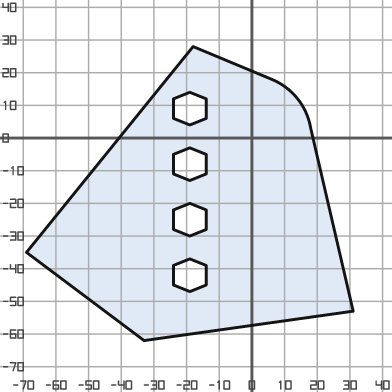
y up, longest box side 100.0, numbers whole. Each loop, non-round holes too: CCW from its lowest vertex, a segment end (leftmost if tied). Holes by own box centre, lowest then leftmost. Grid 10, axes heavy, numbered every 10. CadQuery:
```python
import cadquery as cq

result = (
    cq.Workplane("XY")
    .moveTo(-33.0, -62.0)
    .lineTo(31.0, -53.0)
    .lineTo(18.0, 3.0)
    .threePointArc((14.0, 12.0), (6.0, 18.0))
    .lineTo(-18.0, 28.0)
    .lineTo(-69.0, -35.0)
    .close()
    .moveTo(-19.0, -47.0)
    .lineTo(-14.0, -45.0)
    .lineTo(-14.0, -39.0)
    .lineTo(-19.0, -37.0)
    .lineTo(-24.0, -39.0)
    .lineTo(-24.0, -45.0)
    .close()
    .moveTo(-19.0, -30.0)
    .lineTo(-14.0, -28.0)
    .lineTo(-14.0, -22.0)
    .lineTo(-19.0, -20.0)
    .lineTo(-24.0, -22.0)
    .lineTo(-24.0, -28.0)
    .close()
    .moveTo(-19.0, -13.0)
    .lineTo(-14.0, -11.0)
    .lineTo(-14.0, -5.0)
    .lineTo(-19.0, -3.0)
    .lineTo(-24.0, -5.0)
    .lineTo(-24.0, -11.0)
    .close()
    .moveTo(-19.0, 4.0)
    .lineTo(-14.0, 6.0)
    .lineTo(-14.0, 12.0)
    .lineTo(-19.0, 14.0)
    .lineTo(-24.0, 12.0)
    .lineTo(-24.0, 6.0)
    .close()
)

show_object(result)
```